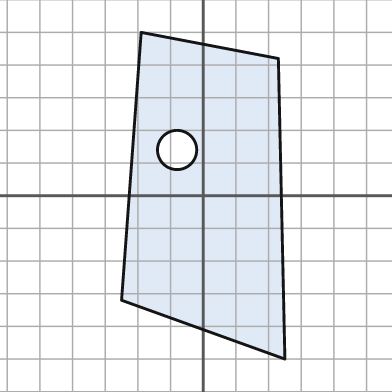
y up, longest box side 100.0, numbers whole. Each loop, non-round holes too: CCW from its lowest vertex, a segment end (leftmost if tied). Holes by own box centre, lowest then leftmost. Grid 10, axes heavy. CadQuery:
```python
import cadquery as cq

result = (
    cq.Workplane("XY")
    .moveTo(25.0, -50.0)
    .lineTo(23.0, 42.0)
    .lineTo(-19.0, 50.0)
    .lineTo(-25.0, -32.0)
    .close()
    .moveTo(-8.0, 14.0)
    .circle(6.0)
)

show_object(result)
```